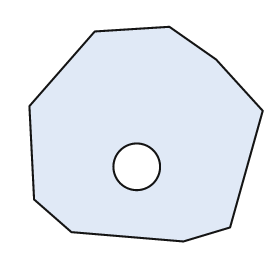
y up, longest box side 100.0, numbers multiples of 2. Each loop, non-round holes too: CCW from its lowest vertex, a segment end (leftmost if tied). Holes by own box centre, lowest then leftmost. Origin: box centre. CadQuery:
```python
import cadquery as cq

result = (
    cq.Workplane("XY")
    .moveTo(16.0, -46.0)
    .lineTo(36.0, -40.0)
    .lineTo(50.0, 10.0)
    .lineTo(30.0, 32.0)
    .lineTo(10.0, 46.0)
    .lineTo(-22.0, 44.0)
    .lineTo(-50.0, 12.0)
    .lineTo(-48.0, -28.0)
    .lineTo(-32.0, -42.0)
    .close()
    .moveTo(-4.0, -14.0)
    .circle(10.0)
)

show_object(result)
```